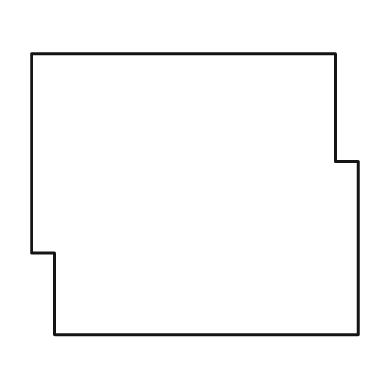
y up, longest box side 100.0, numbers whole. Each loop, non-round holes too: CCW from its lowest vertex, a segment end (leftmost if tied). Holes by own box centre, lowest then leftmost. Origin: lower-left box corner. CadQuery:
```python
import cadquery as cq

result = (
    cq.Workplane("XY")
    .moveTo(7.0, 0.0)
    .lineTo(100.0, 0.0)
    .lineTo(100.0, 53.0)
    .lineTo(93.0, 53.0)
    .lineTo(93.0, 86.0)
    .lineTo(0.0, 86.0)
    .lineTo(0.0, 25.0)
    .lineTo(7.0, 25.0)
    .close()
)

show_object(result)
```